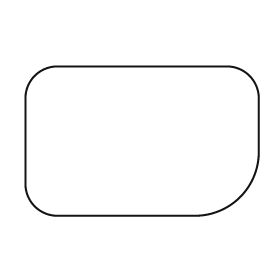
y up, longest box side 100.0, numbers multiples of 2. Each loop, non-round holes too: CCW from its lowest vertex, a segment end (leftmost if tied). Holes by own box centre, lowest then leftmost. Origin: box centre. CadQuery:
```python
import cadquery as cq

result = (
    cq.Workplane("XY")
    .moveTo(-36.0, -32.0)
    .lineTo(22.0, -32.0)
    .threePointArc((42.0, -24.0), (50.0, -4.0))
    .lineTo(50.0, 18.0)
    .threePointArc((46.0, 28.0), (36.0, 32.0))
    .lineTo(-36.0, 32.0)
    .threePointArc((-46.0, 28.0), (-50.0, 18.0))
    .lineTo(-50.0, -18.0)
    .threePointArc((-46.0, -28.0), (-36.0, -32.0))
    .close()
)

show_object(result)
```